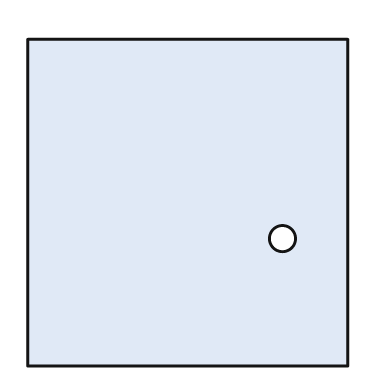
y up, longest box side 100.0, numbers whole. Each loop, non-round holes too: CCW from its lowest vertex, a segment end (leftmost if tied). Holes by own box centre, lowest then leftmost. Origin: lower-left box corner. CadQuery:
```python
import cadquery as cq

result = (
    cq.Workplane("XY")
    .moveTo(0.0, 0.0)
    .lineTo(98.0, 0.0)
    .lineTo(98.0, 100.0)
    .lineTo(0.0, 100.0)
    .close()
    .moveTo(78.0, 39.0)
    .circle(4.0)
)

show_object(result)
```